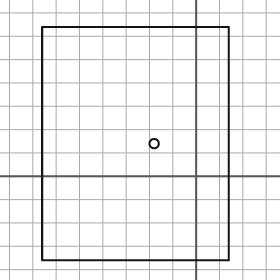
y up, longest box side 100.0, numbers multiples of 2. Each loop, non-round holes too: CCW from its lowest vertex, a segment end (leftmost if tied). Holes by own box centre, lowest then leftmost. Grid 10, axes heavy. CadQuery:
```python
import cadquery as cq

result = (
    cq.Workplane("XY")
    .moveTo(-66.0, -36.0)
    .lineTo(14.0, -36.0)
    .lineTo(14.0, 64.0)
    .lineTo(-66.0, 64.0)
    .close()
    .moveTo(-18.0, 14.0)
    .circle(2.0)
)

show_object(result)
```